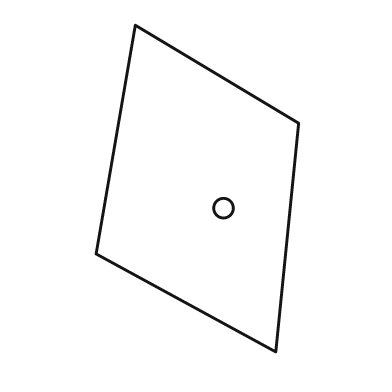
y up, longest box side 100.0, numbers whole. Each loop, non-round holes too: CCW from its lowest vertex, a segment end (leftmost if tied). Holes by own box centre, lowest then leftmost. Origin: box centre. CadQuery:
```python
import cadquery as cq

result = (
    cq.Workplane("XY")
    .moveTo(24.0, -50.0)
    .lineTo(31.0, 20.0)
    .lineTo(-19.0, 50.0)
    .lineTo(-31.0, -20.0)
    .close()
    .moveTo(8.0, -6.0)
    .circle(3.0)
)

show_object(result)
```